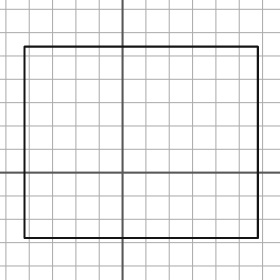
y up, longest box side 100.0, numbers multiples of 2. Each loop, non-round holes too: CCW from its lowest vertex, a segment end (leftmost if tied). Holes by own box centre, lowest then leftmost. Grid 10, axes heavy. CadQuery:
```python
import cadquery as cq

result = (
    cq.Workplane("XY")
    .moveTo(-42.0, -28.0)
    .lineTo(58.0, -28.0)
    .lineTo(58.0, 54.0)
    .lineTo(-42.0, 54.0)
    .close()
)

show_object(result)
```